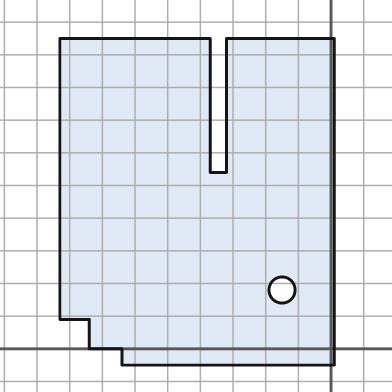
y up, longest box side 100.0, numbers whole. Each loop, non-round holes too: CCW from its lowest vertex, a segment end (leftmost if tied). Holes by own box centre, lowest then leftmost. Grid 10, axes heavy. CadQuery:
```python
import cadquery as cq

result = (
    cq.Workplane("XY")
    .moveTo(-64.0, -5.0)
    .lineTo(1.0, -5.0)
    .lineTo(1.0, 95.0)
    .lineTo(-32.0, 95.0)
    .lineTo(-32.0, 54.0)
    .lineTo(-37.0, 54.0)
    .lineTo(-37.0, 95.0)
    .lineTo(-83.0, 95.0)
    .lineTo(-83.0, 9.0)
    .lineTo(-74.0, 9.0)
    .lineTo(-74.0, 0.0)
    .lineTo(-64.0, 0.0)
    .close()
    .moveTo(-15.0, 18.0)
    .circle(4.0)
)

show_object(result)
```